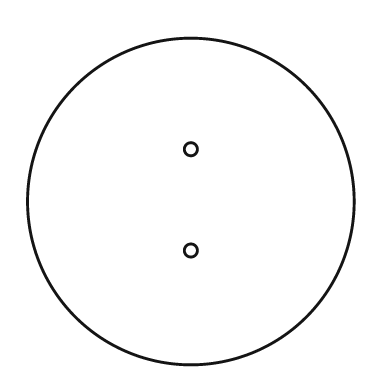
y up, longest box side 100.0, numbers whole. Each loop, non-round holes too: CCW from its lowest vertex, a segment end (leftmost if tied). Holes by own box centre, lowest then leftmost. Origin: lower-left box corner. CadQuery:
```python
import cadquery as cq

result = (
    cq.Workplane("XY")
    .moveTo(50.0, 50.0)
    .circle(50.0)
    .moveTo(50.0, 35.0)
    .circle(2.0)
    .moveTo(50.0, 66.0)
    .circle(2.0)
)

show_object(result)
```